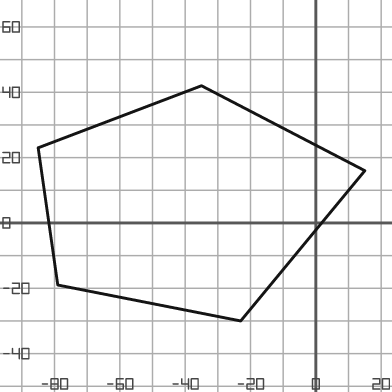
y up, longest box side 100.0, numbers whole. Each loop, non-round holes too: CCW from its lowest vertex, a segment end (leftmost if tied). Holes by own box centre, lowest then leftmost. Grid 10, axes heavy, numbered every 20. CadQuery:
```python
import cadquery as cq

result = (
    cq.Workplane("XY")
    .moveTo(-23.0, -30.0)
    .lineTo(15.0, 16.0)
    .lineTo(-35.0, 42.0)
    .lineTo(-85.0, 23.0)
    .lineTo(-79.0, -19.0)
    .close()
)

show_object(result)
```